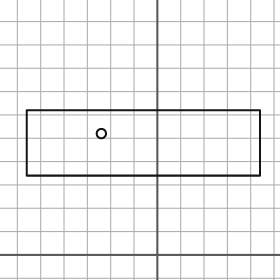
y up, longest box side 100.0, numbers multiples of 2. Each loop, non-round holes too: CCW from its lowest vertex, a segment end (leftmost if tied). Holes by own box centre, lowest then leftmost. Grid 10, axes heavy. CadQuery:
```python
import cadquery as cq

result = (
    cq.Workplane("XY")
    .moveTo(-56.0, 34.0)
    .lineTo(44.0, 34.0)
    .lineTo(44.0, 62.0)
    .lineTo(-56.0, 62.0)
    .close()
    .moveTo(-24.0, 52.0)
    .circle(2.0)
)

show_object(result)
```